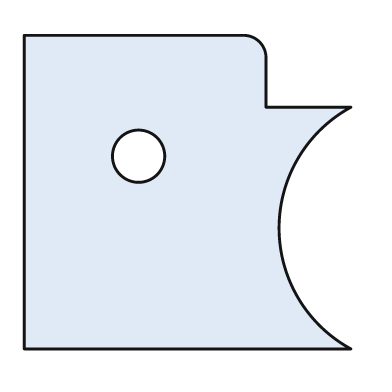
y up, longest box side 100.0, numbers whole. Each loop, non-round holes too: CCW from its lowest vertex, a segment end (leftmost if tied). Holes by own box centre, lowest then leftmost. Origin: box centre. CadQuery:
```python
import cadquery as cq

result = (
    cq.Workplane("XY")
    .moveTo(-50.0, -48.0)
    .lineTo(50.0, -48.0)
    .threePointArc((28.0, -11.0), (50.0, 26.0))
    .lineTo(24.0, 26.0)
    .lineTo(24.0, 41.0)
    .threePointArc((22.0, 46.0), (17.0, 48.0))
    .lineTo(-50.0, 48.0)
    .close()
    .moveTo(-15.0, 11.0)
    .circle(8.0)
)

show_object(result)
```